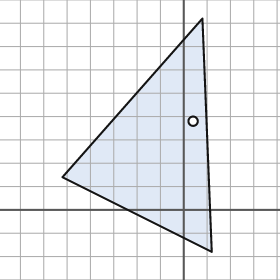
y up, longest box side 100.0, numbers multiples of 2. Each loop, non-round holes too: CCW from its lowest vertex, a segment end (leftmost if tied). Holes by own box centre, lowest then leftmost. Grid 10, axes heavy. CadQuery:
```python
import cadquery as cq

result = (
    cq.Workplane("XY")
    .moveTo(12.0, -18.0)
    .lineTo(8.0, 82.0)
    .lineTo(-52.0, 14.0)
    .close()
    .moveTo(4.0, 38.0)
    .circle(2.0)
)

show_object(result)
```